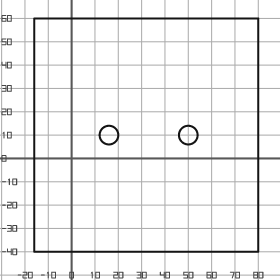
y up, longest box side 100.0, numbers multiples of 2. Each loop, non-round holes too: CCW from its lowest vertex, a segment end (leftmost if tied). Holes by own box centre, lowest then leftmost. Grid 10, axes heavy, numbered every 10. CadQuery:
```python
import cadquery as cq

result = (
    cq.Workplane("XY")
    .moveTo(-16.0, -40.0)
    .lineTo(80.0, -40.0)
    .lineTo(80.0, 60.0)
    .lineTo(-16.0, 60.0)
    .close()
    .moveTo(16.0, 10.0)
    .circle(4.0)
    .moveTo(50.0, 10.0)
    .circle(4.0)
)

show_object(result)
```